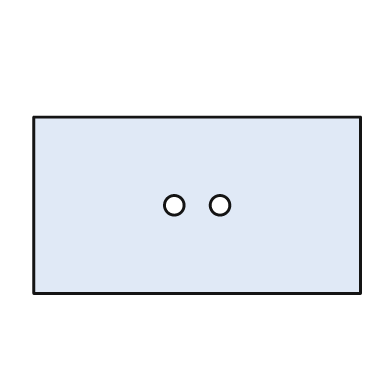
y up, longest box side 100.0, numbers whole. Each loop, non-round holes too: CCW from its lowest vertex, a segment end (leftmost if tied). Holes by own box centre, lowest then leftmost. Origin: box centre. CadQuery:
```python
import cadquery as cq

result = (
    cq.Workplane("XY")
    .moveTo(-50.0, -27.0)
    .lineTo(50.0, -27.0)
    .lineTo(50.0, 27.0)
    .lineTo(-50.0, 27.0)
    .close()
    .moveTo(-7.0, 0.0)
    .circle(3.0)
    .moveTo(7.0, 0.0)
    .circle(3.0)
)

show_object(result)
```